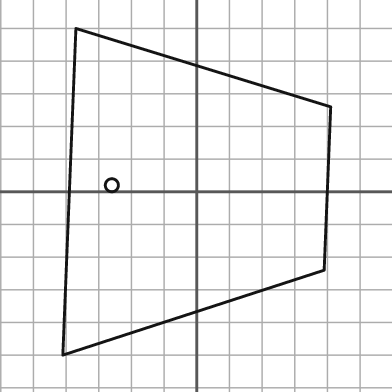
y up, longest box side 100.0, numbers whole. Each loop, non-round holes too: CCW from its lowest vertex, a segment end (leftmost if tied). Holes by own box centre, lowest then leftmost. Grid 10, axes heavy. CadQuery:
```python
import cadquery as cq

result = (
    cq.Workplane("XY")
    .moveTo(-41.0, -50.0)
    .lineTo(39.0, -24.0)
    .lineTo(41.0, 26.0)
    .lineTo(-37.0, 50.0)
    .close()
    .moveTo(-26.0, 2.0)
    .circle(2.0)
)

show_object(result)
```